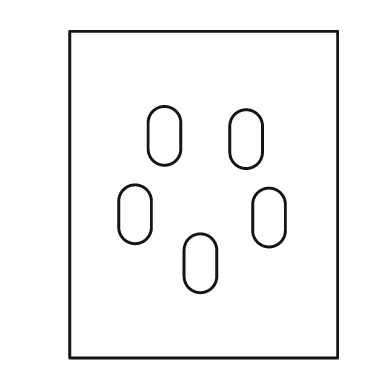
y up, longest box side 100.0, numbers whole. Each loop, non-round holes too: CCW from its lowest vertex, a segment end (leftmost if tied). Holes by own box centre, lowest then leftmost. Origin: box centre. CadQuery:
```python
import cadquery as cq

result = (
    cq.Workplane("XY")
    .moveTo(-41.0, -50.0)
    .lineTo(41.0, -50.0)
    .lineTo(41.0, 50.0)
    .lineTo(-41.0, 50.0)
    .close()
    .moveTo(-6.0, -25.0)
    .threePointArc((-1.0, -30.0), (4.0, -25.0))
    .lineTo(4.0, -17.0)
    .threePointArc((-1.0, -12.0), (-6.0, -17.0))
    .close()
    .moveTo(15.0, -11.0)
    .threePointArc((20.0, -16.0), (25.0, -11.0))
    .lineTo(25.0, -3.0)
    .threePointArc((20.0, 2.0), (15.0, -3.0))
    .close()
    .moveTo(-26.0, -10.0)
    .threePointArc((-21.0, -15.0), (-16.0, -10.0))
    .lineTo(-16.0, -2.0)
    .threePointArc((-21.0, 3.0), (-26.0, -2.0))
    .close()
    .moveTo(8.0, 13.0)
    .threePointArc((13.0, 8.0), (18.0, 13.0))
    .lineTo(18.0, 21.0)
    .threePointArc((13.0, 26.0), (8.0, 21.0))
    .close()
    .moveTo(-17.0, 14.0)
    .threePointArc((-12.0, 9.0), (-7.0, 14.0))
    .lineTo(-7.0, 22.0)
    .threePointArc((-12.0, 27.0), (-17.0, 22.0))
    .close()
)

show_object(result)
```